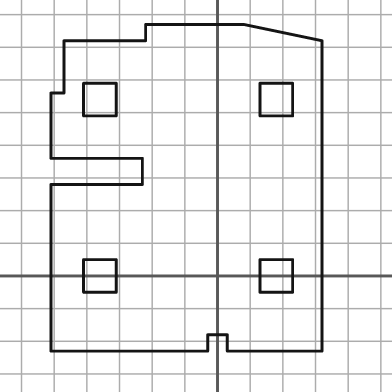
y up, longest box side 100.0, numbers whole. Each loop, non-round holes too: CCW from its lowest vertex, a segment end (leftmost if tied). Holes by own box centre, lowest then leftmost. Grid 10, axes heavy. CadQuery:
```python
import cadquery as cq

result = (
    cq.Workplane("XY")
    .moveTo(-51.0, -23.0)
    .lineTo(-3.0, -23.0)
    .lineTo(-3.0, -18.0)
    .lineTo(3.0, -18.0)
    .lineTo(3.0, -23.0)
    .lineTo(32.0, -23.0)
    .lineTo(32.0, 72.0)
    .lineTo(8.0, 77.0)
    .lineTo(-22.0, 77.0)
    .lineTo(-22.0, 72.0)
    .lineTo(-47.0, 72.0)
    .lineTo(-47.0, 56.0)
    .lineTo(-51.0, 56.0)
    .lineTo(-51.0, 36.0)
    .lineTo(-23.0, 36.0)
    .lineTo(-23.0, 28.0)
    .lineTo(-51.0, 28.0)
    .close()
    .moveTo(-41.0, -5.0)
    .lineTo(-31.0, -5.0)
    .lineTo(-31.0, 5.0)
    .lineTo(-41.0, 5.0)
    .close()
    .moveTo(13.0, -5.0)
    .lineTo(23.0, -5.0)
    .lineTo(23.0, 5.0)
    .lineTo(13.0, 5.0)
    .close()
    .moveTo(-41.0, 49.0)
    .lineTo(-31.0, 49.0)
    .lineTo(-31.0, 59.0)
    .lineTo(-41.0, 59.0)
    .close()
    .moveTo(13.0, 49.0)
    .lineTo(23.0, 49.0)
    .lineTo(23.0, 59.0)
    .lineTo(13.0, 59.0)
    .close()
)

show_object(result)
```